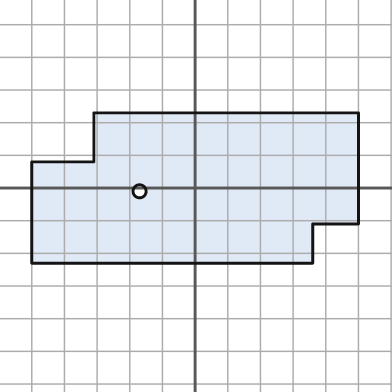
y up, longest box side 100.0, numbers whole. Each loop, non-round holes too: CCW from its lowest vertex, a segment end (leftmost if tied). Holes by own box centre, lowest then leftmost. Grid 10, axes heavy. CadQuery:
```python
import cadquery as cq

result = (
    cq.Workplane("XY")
    .moveTo(-50.0, -23.0)
    .lineTo(36.0, -23.0)
    .lineTo(36.0, -11.0)
    .lineTo(50.0, -11.0)
    .lineTo(50.0, 23.0)
    .lineTo(-31.0, 23.0)
    .lineTo(-31.0, 8.0)
    .lineTo(-50.0, 8.0)
    .close()
    .moveTo(-17.0, -1.0)
    .circle(2.0)
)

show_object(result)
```